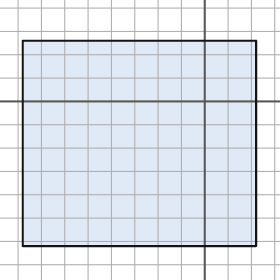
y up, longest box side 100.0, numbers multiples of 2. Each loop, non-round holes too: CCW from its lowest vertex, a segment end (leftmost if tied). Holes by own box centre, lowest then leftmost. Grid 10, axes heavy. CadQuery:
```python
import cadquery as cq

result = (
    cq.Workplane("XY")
    .moveTo(-78.0, -62.0)
    .lineTo(22.0, -62.0)
    .lineTo(22.0, 26.0)
    .lineTo(-78.0, 26.0)
    .close()
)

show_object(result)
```